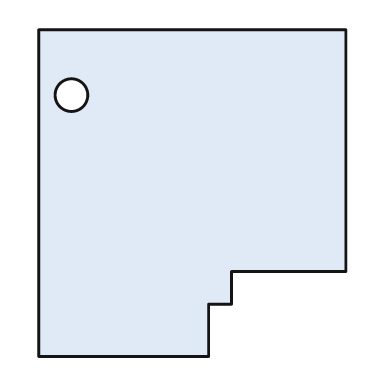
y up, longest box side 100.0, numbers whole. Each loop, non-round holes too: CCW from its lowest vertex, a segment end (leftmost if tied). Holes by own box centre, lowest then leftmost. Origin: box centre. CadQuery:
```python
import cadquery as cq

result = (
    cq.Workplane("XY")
    .moveTo(-47.0, -50.0)
    .lineTo(5.0, -50.0)
    .lineTo(5.0, -34.0)
    .lineTo(12.0, -34.0)
    .lineTo(12.0, -24.0)
    .lineTo(47.0, -24.0)
    .lineTo(47.0, 50.0)
    .lineTo(-47.0, 50.0)
    .close()
    .moveTo(-37.0, 30.0)
    .circle(5.0)
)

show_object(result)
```